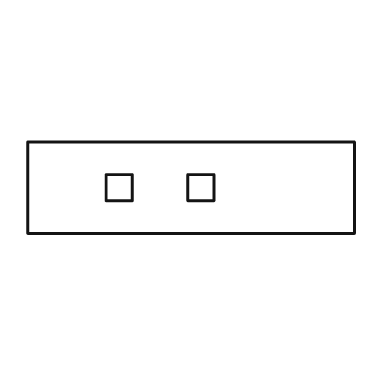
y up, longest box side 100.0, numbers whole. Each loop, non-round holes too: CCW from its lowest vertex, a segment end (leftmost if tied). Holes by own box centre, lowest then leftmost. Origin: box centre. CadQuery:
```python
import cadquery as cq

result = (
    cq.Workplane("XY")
    .moveTo(-50.0, -14.0)
    .lineTo(50.0, -14.0)
    .lineTo(50.0, 14.0)
    .lineTo(-50.0, 14.0)
    .close()
    .moveTo(-26.0, -4.0)
    .lineTo(-18.0, -4.0)
    .lineTo(-18.0, 4.0)
    .lineTo(-26.0, 4.0)
    .close()
    .moveTo(-1.0, -4.0)
    .lineTo(7.0, -4.0)
    .lineTo(7.0, 4.0)
    .lineTo(-1.0, 4.0)
    .close()
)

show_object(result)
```